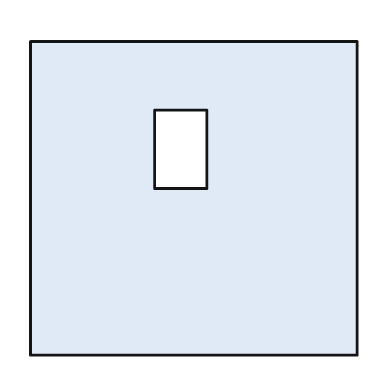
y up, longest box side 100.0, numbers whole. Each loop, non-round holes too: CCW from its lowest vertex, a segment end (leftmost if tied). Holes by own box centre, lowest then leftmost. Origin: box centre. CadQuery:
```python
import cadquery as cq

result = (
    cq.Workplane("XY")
    .moveTo(-50.0, -48.0)
    .lineTo(50.0, -48.0)
    .lineTo(50.0, 48.0)
    .lineTo(-50.0, 48.0)
    .close()
    .moveTo(-12.0, 3.0)
    .lineTo(4.0, 3.0)
    .lineTo(4.0, 27.0)
    .lineTo(-12.0, 27.0)
    .close()
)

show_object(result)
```